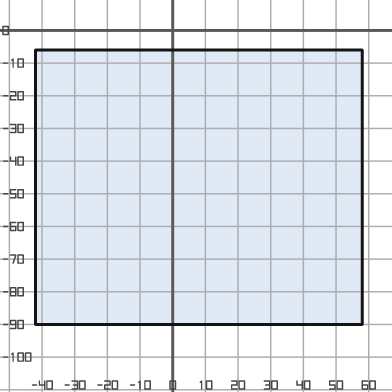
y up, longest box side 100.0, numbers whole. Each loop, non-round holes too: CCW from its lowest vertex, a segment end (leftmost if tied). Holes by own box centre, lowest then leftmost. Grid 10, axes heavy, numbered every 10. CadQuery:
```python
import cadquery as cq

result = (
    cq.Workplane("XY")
    .moveTo(-42.0, -90.0)
    .lineTo(58.0, -90.0)
    .lineTo(58.0, -6.0)
    .lineTo(-42.0, -6.0)
    .close()
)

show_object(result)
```